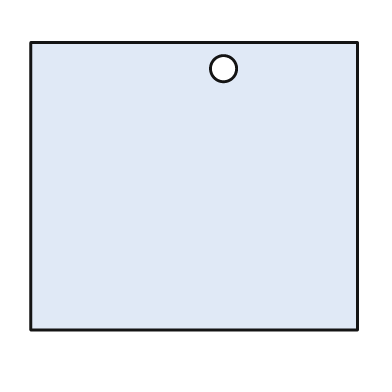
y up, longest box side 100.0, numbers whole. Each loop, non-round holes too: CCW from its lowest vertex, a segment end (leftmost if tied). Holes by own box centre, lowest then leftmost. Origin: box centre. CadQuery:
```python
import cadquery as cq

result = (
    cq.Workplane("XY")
    .moveTo(-50.0, -44.0)
    .lineTo(50.0, -44.0)
    .lineTo(50.0, 44.0)
    .lineTo(-50.0, 44.0)
    .close()
    .moveTo(9.0, 36.0)
    .circle(4.0)
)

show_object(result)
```